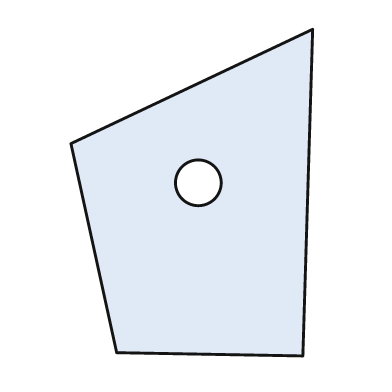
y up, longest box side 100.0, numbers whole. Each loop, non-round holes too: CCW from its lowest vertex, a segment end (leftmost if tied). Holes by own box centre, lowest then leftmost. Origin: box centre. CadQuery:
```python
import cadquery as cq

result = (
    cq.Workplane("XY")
    .moveTo(34.0, -50.0)
    .lineTo(37.0, 50.0)
    .lineTo(-37.0, 15.0)
    .lineTo(-23.0, -49.0)
    .close()
    .moveTo(2.0, 3.0)
    .circle(7.0)
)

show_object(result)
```